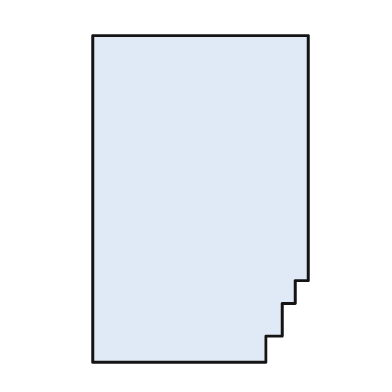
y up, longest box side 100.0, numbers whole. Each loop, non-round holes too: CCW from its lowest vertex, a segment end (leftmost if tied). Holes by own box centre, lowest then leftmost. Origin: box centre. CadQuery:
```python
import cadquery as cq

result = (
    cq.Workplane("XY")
    .moveTo(-33.0, -50.0)
    .lineTo(20.0, -50.0)
    .lineTo(20.0, -42.0)
    .lineTo(25.0, -42.0)
    .lineTo(25.0, -32.0)
    .lineTo(29.0, -32.0)
    .lineTo(29.0, -25.0)
    .lineTo(33.0, -25.0)
    .lineTo(33.0, 50.0)
    .lineTo(-33.0, 50.0)
    .close()
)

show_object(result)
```